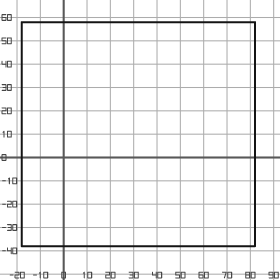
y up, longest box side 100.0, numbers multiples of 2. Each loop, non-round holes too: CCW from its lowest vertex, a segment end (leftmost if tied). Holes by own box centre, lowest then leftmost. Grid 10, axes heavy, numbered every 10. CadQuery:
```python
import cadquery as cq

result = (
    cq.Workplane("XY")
    .moveTo(-18.0, -38.0)
    .lineTo(82.0, -38.0)
    .lineTo(82.0, 58.0)
    .lineTo(-18.0, 58.0)
    .close()
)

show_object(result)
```